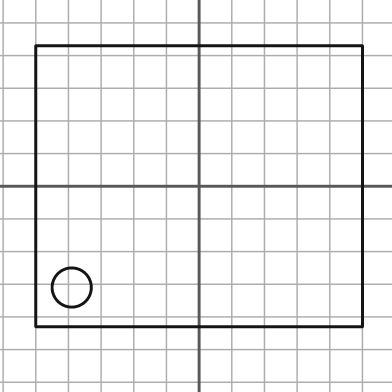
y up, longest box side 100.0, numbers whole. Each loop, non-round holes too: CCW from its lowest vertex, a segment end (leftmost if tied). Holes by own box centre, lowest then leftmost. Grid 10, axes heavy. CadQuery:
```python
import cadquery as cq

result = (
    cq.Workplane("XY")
    .moveTo(-50.0, -43.0)
    .lineTo(50.0, -43.0)
    .lineTo(50.0, 43.0)
    .lineTo(-50.0, 43.0)
    .close()
    .moveTo(-39.0, -31.0)
    .circle(6.0)
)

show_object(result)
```